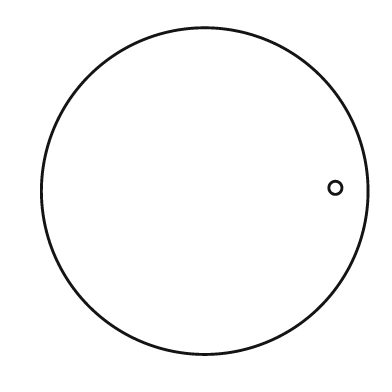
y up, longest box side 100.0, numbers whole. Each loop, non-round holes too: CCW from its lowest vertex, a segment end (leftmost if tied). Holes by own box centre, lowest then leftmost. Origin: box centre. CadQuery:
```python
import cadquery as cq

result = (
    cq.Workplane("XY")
    .moveTo(0.0, 0.0)
    .circle(50.0)
    .moveTo(40.0, 1.0)
    .circle(2.0)
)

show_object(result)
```